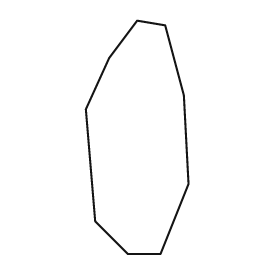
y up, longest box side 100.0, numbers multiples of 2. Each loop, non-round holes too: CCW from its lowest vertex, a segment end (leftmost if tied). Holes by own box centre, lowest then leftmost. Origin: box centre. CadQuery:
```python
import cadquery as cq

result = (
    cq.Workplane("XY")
    .moveTo(-4.0, -50.0)
    .lineTo(10.0, -50.0)
    .lineTo(22.0, -20.0)
    .lineTo(20.0, 18.0)
    .lineTo(12.0, 48.0)
    .lineTo(0.0, 50.0)
    .lineTo(-12.0, 34.0)
    .lineTo(-22.0, 12.0)
    .lineTo(-18.0, -36.0)
    .close()
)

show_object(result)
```